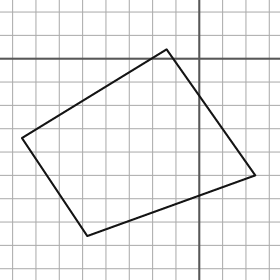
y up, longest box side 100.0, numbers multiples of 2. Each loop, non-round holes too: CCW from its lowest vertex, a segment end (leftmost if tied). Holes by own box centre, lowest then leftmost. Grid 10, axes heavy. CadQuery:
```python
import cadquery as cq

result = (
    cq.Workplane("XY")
    .moveTo(-48.0, -76.0)
    .lineTo(24.0, -50.0)
    .lineTo(-14.0, 4.0)
    .lineTo(-76.0, -34.0)
    .close()
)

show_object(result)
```